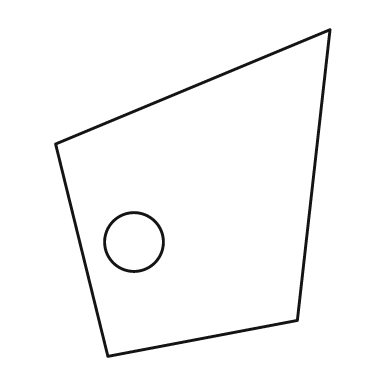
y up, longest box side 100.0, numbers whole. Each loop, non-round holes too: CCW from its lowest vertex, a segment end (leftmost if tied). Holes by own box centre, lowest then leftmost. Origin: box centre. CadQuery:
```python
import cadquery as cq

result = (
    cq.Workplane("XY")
    .moveTo(-26.0, -50.0)
    .lineTo(32.0, -39.0)
    .lineTo(42.0, 50.0)
    .lineTo(-42.0, 15.0)
    .close()
    .moveTo(-18.0, -15.0)
    .circle(9.0)
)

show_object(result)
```